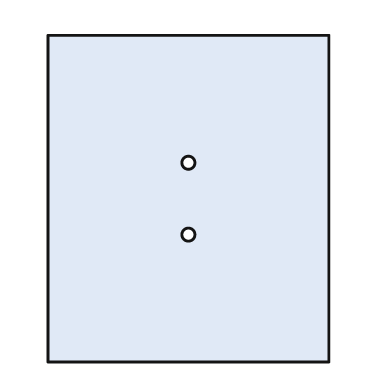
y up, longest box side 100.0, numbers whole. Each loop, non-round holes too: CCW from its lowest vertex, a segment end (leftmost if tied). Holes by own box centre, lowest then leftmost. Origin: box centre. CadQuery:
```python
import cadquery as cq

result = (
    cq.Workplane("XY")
    .moveTo(-43.0, -50.0)
    .lineTo(43.0, -50.0)
    .lineTo(43.0, 50.0)
    .lineTo(-43.0, 50.0)
    .close()
    .moveTo(0.0, -11.0)
    .circle(2.0)
    .moveTo(0.0, 11.0)
    .circle(2.0)
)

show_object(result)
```